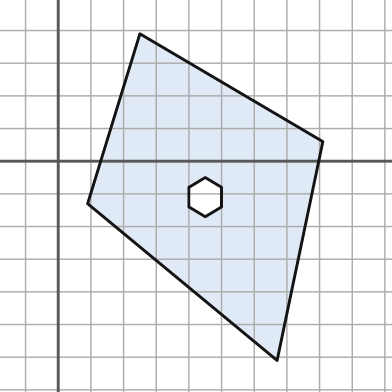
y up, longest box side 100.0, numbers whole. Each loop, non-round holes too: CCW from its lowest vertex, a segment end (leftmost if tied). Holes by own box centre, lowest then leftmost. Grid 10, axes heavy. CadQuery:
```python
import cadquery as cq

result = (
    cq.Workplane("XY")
    .moveTo(67.0, -61.0)
    .lineTo(81.0, 6.0)
    .lineTo(25.0, 39.0)
    .lineTo(9.0, -13.0)
    .close()
    .moveTo(45.0, -17.0)
    .lineTo(50.0, -14.0)
    .lineTo(50.0, -8.0)
    .lineTo(45.0, -5.0)
    .lineTo(40.0, -8.0)
    .lineTo(40.0, -14.0)
    .close()
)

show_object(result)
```